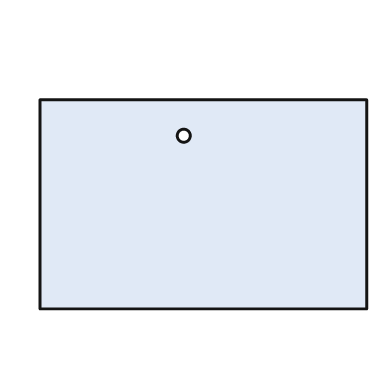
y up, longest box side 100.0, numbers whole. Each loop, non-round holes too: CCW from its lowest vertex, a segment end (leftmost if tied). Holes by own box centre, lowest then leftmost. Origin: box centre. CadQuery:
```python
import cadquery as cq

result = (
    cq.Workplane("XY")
    .moveTo(-50.0, -32.0)
    .lineTo(50.0, -32.0)
    .lineTo(50.0, 32.0)
    .lineTo(-50.0, 32.0)
    .close()
    .moveTo(-6.0, 21.0)
    .circle(2.0)
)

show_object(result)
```